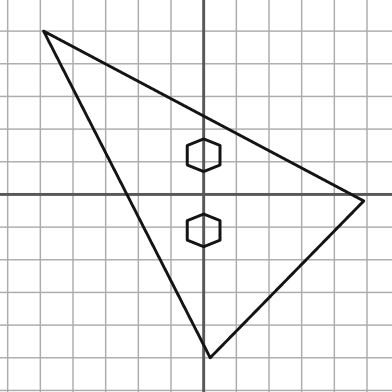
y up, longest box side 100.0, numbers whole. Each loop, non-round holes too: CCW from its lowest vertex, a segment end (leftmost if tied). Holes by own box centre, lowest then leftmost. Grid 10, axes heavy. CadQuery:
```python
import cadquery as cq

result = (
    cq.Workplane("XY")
    .moveTo(2.0, -50.0)
    .lineTo(49.0, -2.0)
    .lineTo(-49.0, 50.0)
    .close()
    .moveTo(0.0, -16.0)
    .lineTo(5.0, -14.0)
    .lineTo(5.0, -8.0)
    .lineTo(0.0, -6.0)
    .lineTo(-5.0, -8.0)
    .lineTo(-5.0, -14.0)
    .close()
    .moveTo(0.0, 7.0)
    .lineTo(5.0, 9.0)
    .lineTo(5.0, 15.0)
    .lineTo(0.0, 17.0)
    .lineTo(-5.0, 15.0)
    .lineTo(-5.0, 9.0)
    .close()
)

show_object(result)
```